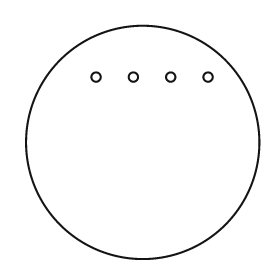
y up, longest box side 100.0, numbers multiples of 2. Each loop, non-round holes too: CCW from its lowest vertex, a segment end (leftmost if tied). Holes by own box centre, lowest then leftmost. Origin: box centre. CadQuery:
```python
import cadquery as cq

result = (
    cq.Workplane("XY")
    .moveTo(0.0, 0.0)
    .circle(50.0)
    .moveTo(-20.0, 28.0)
    .circle(2.0)
    .moveTo(-4.0, 28.0)
    .circle(2.0)
    .moveTo(12.0, 28.0)
    .circle(2.0)
    .moveTo(28.0, 28.0)
    .circle(2.0)
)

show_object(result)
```